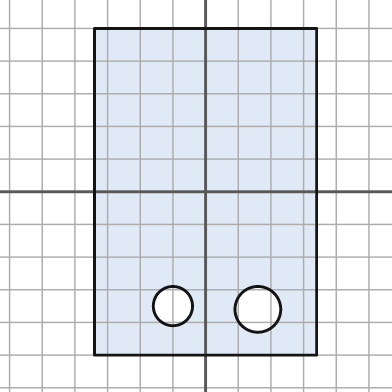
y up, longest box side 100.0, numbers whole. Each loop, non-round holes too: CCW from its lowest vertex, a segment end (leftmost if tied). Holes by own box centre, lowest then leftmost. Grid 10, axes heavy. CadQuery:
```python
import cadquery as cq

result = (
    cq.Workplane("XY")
    .moveTo(-34.0, -50.0)
    .lineTo(34.0, -50.0)
    .lineTo(34.0, 50.0)
    .lineTo(-34.0, 50.0)
    .close()
    .moveTo(16.0, -36.0)
    .circle(7.0)
    .moveTo(-10.0, -35.0)
    .circle(6.0)
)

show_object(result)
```